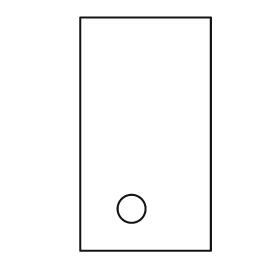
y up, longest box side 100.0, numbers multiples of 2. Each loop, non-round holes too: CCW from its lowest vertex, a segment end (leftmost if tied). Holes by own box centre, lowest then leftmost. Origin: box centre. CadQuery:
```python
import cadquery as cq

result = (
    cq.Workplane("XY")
    .moveTo(-28.0, -50.0)
    .lineTo(28.0, -50.0)
    .lineTo(28.0, 50.0)
    .lineTo(-28.0, 50.0)
    .close()
    .moveTo(-6.0, -32.0)
    .circle(6.0)
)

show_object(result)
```